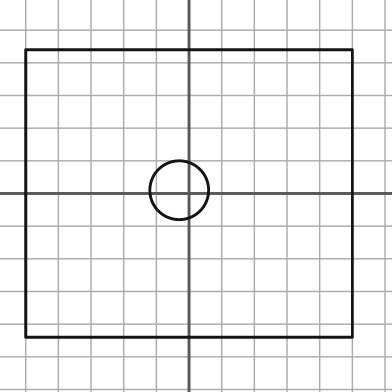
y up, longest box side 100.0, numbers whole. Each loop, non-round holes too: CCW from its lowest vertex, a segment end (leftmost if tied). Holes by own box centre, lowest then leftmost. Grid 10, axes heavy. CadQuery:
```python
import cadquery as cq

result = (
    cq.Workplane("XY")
    .moveTo(-50.0, -44.0)
    .lineTo(50.0, -44.0)
    .lineTo(50.0, 44.0)
    .lineTo(-50.0, 44.0)
    .close()
    .moveTo(-3.0, 1.0)
    .circle(9.0)
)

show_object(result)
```